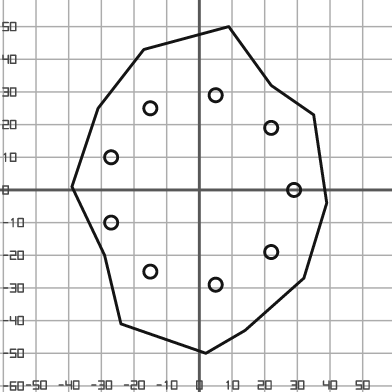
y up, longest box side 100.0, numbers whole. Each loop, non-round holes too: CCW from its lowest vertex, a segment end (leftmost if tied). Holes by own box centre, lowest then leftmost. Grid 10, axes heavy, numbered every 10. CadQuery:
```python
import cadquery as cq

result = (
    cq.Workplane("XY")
    .moveTo(2.0, -50.0)
    .lineTo(14.0, -43.0)
    .lineTo(32.0, -27.0)
    .lineTo(39.0, -4.0)
    .lineTo(35.0, 23.0)
    .lineTo(22.0, 32.0)
    .lineTo(9.0, 50.0)
    .lineTo(-17.0, 43.0)
    .lineTo(-31.0, 25.0)
    .lineTo(-39.0, 1.0)
    .lineTo(-29.0, -20.0)
    .lineTo(-24.0, -41.0)
    .close()
    .moveTo(5.0, -29.0)
    .circle(2.0)
    .moveTo(-15.0, -25.0)
    .circle(2.0)
    .moveTo(22.0, -19.0)
    .circle(2.0)
    .moveTo(-27.0, -10.0)
    .circle(2.0)
    .moveTo(29.0, 0.0)
    .circle(2.0)
    .moveTo(-27.0, 10.0)
    .circle(2.0)
    .moveTo(22.0, 19.0)
    .circle(2.0)
    .moveTo(-15.0, 25.0)
    .circle(2.0)
    .moveTo(5.0, 29.0)
    .circle(2.0)
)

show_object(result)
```